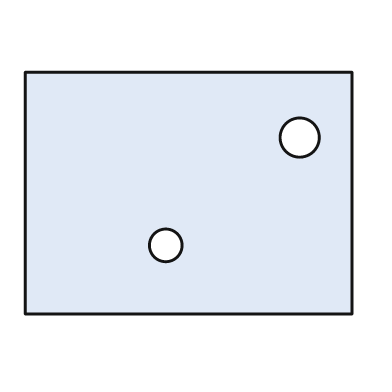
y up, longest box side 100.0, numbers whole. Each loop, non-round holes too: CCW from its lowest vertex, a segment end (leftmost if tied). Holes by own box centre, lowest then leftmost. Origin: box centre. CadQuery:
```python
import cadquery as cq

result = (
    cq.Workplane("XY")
    .moveTo(-50.0, -37.0)
    .lineTo(50.0, -37.0)
    .lineTo(50.0, 37.0)
    .lineTo(-50.0, 37.0)
    .close()
    .moveTo(-7.0, -16.0)
    .circle(5.0)
    .moveTo(34.0, 17.0)
    .circle(6.0)
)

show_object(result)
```